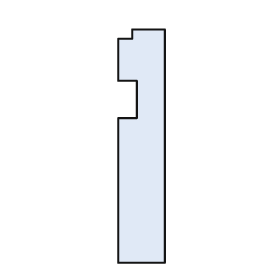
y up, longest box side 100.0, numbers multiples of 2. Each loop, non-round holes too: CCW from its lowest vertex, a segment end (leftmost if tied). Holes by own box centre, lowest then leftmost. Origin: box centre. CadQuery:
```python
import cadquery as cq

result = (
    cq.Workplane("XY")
    .moveTo(-10.0, -50.0)
    .lineTo(10.0, -50.0)
    .lineTo(10.0, 50.0)
    .lineTo(-4.0, 50.0)
    .lineTo(-4.0, 46.0)
    .lineTo(-10.0, 46.0)
    .lineTo(-10.0, 28.0)
    .lineTo(-2.0, 28.0)
    .lineTo(-2.0, 12.0)
    .lineTo(-10.0, 12.0)
    .close()
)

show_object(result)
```